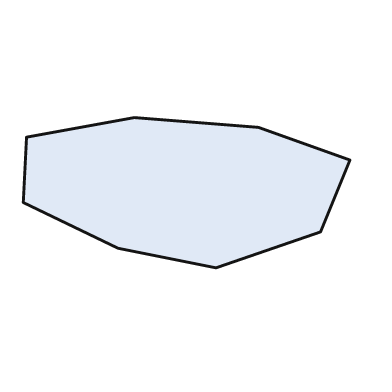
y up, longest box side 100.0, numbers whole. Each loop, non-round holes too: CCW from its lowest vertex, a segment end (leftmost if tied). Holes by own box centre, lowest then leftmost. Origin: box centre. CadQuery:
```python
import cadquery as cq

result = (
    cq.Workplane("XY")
    .moveTo(9.0, -23.0)
    .lineTo(41.0, -12.0)
    .lineTo(50.0, 10.0)
    .lineTo(22.0, 20.0)
    .lineTo(-16.0, 23.0)
    .lineTo(-49.0, 17.0)
    .lineTo(-50.0, -3.0)
    .lineTo(-21.0, -17.0)
    .close()
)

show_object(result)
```